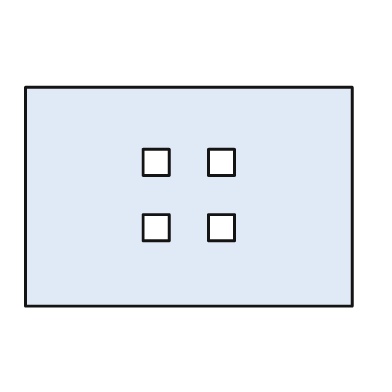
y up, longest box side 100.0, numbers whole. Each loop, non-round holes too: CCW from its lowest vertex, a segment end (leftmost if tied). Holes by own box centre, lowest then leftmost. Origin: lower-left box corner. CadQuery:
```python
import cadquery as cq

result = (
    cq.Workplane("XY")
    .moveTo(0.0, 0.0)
    .lineTo(100.0, 0.0)
    .lineTo(100.0, 67.0)
    .lineTo(0.0, 67.0)
    .close()
    .moveTo(36.0, 20.0)
    .lineTo(44.0, 20.0)
    .lineTo(44.0, 28.0)
    .lineTo(36.0, 28.0)
    .close()
    .moveTo(56.0, 20.0)
    .lineTo(64.0, 20.0)
    .lineTo(64.0, 28.0)
    .lineTo(56.0, 28.0)
    .close()
    .moveTo(36.0, 40.0)
    .lineTo(44.0, 40.0)
    .lineTo(44.0, 48.0)
    .lineTo(36.0, 48.0)
    .close()
    .moveTo(56.0, 40.0)
    .lineTo(64.0, 40.0)
    .lineTo(64.0, 48.0)
    .lineTo(56.0, 48.0)
    .close()
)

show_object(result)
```